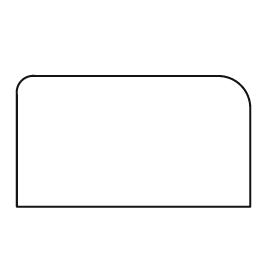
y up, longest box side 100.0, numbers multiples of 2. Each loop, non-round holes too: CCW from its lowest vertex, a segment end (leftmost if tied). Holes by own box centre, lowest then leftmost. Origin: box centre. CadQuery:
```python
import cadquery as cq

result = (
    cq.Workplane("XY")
    .moveTo(-50.0, -28.0)
    .lineTo(50.0, -28.0)
    .lineTo(50.0, 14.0)
    .threePointArc((46.0, 24.0), (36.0, 28.0))
    .lineTo(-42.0, 28.0)
    .threePointArc((-48.0, 26.0), (-50.0, 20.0))
    .close()
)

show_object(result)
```